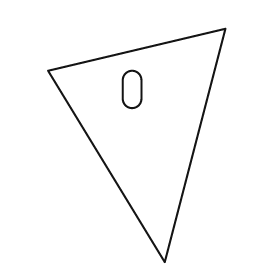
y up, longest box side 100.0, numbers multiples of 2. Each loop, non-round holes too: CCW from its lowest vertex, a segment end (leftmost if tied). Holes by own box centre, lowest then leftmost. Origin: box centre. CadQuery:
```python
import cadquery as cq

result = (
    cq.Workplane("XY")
    .moveTo(12.0, -50.0)
    .lineTo(38.0, 50.0)
    .lineTo(-38.0, 32.0)
    .close()
    .moveTo(-6.0, 20.0)
    .threePointArc((-2.0, 16.0), (2.0, 20.0))
    .lineTo(2.0, 28.0)
    .threePointArc((-2.0, 32.0), (-6.0, 28.0))
    .close()
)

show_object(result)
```